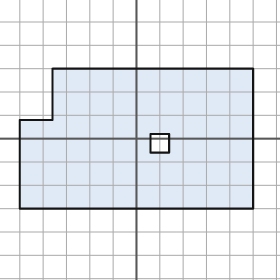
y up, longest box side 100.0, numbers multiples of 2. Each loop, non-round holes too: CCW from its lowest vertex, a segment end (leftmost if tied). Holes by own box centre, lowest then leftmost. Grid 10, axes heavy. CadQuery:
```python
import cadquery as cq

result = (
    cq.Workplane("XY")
    .moveTo(-50.0, -30.0)
    .lineTo(50.0, -30.0)
    .lineTo(50.0, 30.0)
    .lineTo(-36.0, 30.0)
    .lineTo(-36.0, 8.0)
    .lineTo(-50.0, 8.0)
    .close()
    .moveTo(6.0, -6.0)
    .lineTo(14.0, -6.0)
    .lineTo(14.0, 2.0)
    .lineTo(6.0, 2.0)
    .close()
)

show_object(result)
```